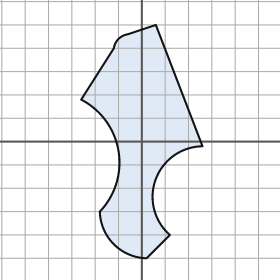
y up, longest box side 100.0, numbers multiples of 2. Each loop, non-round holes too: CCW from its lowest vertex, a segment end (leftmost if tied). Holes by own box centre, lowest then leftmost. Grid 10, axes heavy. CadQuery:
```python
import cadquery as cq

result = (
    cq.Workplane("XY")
    .moveTo(2.0, -50.0)
    .lineTo(12.0, -40.0)
    .threePointArc((6.0, -16.0), (26.0, -2.0))
    .lineTo(6.0, 50.0)
    .lineTo(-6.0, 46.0)
    .threePointArc((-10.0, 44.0), (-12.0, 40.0))
    .lineTo(-26.0, 18.0)
    .threePointArc((-10.0, -4.0), (-18.0, -30.0))
    .threePointArc((-12.0, -44.0), (2.0, -50.0))
    .close()
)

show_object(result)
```